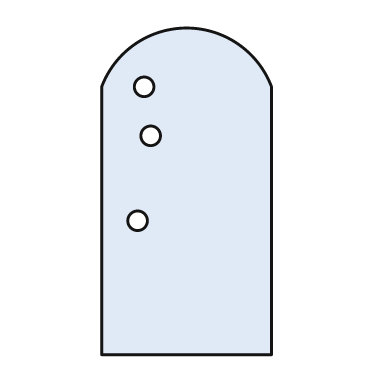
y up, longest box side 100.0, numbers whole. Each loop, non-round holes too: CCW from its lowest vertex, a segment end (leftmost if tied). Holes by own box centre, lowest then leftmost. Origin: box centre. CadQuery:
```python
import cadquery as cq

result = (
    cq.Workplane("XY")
    .moveTo(-26.0, -50.0)
    .lineTo(26.0, -50.0)
    .lineTo(26.0, 32.0)
    .threePointArc((0.0, 50.0), (-26.0, 32.0))
    .close()
    .moveTo(-15.0, -9.0)
    .circle(3.0)
    .moveTo(-11.0, 17.0)
    .circle(3.0)
    .moveTo(-13.0, 32.0)
    .circle(3.0)
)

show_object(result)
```